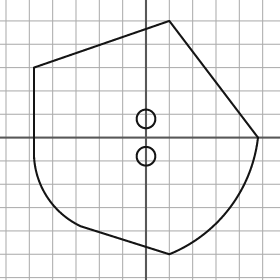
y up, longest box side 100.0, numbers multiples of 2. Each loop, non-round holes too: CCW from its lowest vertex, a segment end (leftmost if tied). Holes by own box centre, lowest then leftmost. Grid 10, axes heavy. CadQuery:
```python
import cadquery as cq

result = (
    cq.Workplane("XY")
    .moveTo(10.0, -50.0)
    .threePointArc((36.0, -30.0), (48.0, 0.0))
    .lineTo(10.0, 50.0)
    .lineTo(-48.0, 30.0)
    .lineTo(-48.0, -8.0)
    .threePointArc((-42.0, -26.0), (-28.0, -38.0))
    .close()
    .moveTo(0.0, -8.0)
    .circle(4.0)
    .moveTo(0.0, 8.0)
    .circle(4.0)
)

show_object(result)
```